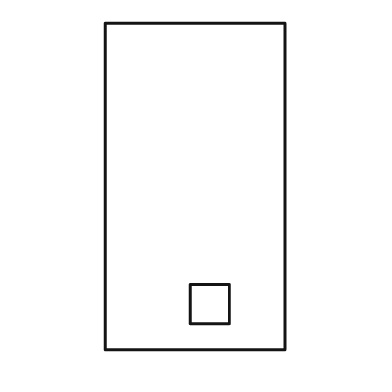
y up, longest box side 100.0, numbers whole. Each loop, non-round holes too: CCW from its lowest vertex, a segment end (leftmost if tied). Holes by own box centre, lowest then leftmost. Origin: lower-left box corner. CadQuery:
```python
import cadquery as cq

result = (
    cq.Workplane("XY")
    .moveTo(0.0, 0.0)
    .lineTo(55.0, 0.0)
    .lineTo(55.0, 100.0)
    .lineTo(0.0, 100.0)
    .close()
    .moveTo(26.0, 8.0)
    .lineTo(38.0, 8.0)
    .lineTo(38.0, 20.0)
    .lineTo(26.0, 20.0)
    .close()
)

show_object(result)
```